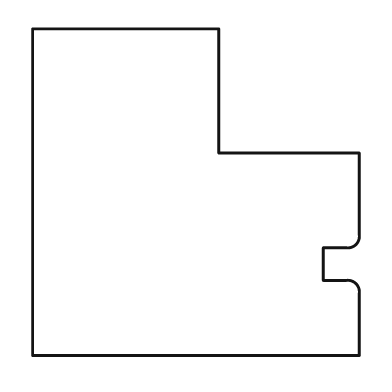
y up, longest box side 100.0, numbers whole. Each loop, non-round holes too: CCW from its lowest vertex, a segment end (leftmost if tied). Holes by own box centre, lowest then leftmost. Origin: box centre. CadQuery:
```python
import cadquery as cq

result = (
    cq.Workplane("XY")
    .moveTo(-50.0, -50.0)
    .lineTo(50.0, -50.0)
    .lineTo(50.0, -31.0)
    .threePointArc((49.0, -28.0), (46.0, -27.0))
    .lineTo(39.0, -27.0)
    .lineTo(39.0, -17.0)
    .lineTo(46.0, -17.0)
    .threePointArc((49.0, -16.0), (50.0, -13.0))
    .lineTo(50.0, 12.0)
    .lineTo(7.0, 12.0)
    .lineTo(7.0, 50.0)
    .lineTo(-50.0, 50.0)
    .close()
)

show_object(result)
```